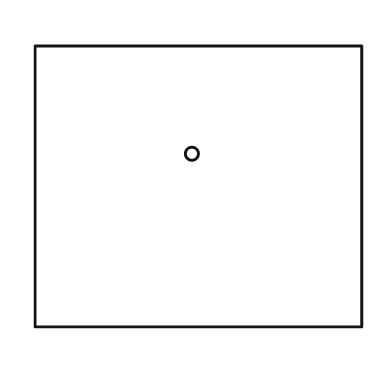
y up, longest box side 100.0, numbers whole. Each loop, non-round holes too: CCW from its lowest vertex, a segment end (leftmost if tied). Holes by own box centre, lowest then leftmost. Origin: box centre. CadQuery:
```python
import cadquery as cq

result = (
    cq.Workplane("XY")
    .moveTo(-50.0, -43.0)
    .lineTo(50.0, -43.0)
    .lineTo(50.0, 43.0)
    .lineTo(-50.0, 43.0)
    .close()
    .moveTo(-2.0, 10.0)
    .circle(2.0)
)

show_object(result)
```